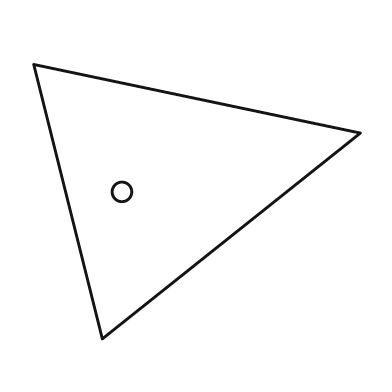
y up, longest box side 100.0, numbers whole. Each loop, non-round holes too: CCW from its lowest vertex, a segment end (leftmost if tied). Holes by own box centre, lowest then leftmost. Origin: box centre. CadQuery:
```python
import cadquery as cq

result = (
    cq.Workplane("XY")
    .moveTo(-29.0, -42.0)
    .lineTo(50.0, 21.0)
    .lineTo(-50.0, 42.0)
    .close()
    .moveTo(-23.0, 3.0)
    .circle(3.0)
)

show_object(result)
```